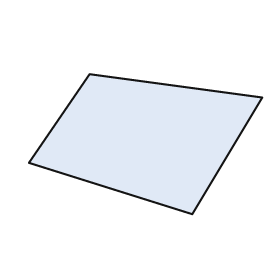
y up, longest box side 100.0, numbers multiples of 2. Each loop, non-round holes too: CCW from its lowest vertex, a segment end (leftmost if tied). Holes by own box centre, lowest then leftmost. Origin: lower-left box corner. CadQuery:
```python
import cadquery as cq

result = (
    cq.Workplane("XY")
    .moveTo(70.0, 0.0)
    .lineTo(100.0, 50.0)
    .lineTo(26.0, 60.0)
    .lineTo(0.0, 22.0)
    .close()
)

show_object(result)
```